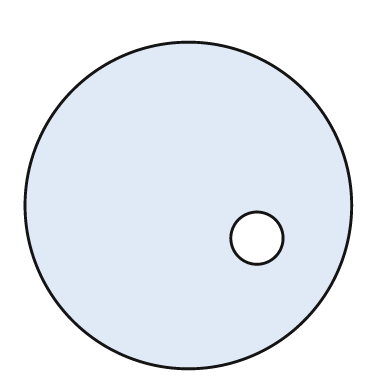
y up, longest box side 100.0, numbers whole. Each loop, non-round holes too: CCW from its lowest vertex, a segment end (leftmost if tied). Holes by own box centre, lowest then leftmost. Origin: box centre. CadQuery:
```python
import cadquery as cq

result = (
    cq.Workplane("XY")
    .moveTo(0.0, 0.0)
    .circle(50.0)
    .moveTo(21.0, -10.0)
    .circle(8.0)
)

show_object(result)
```